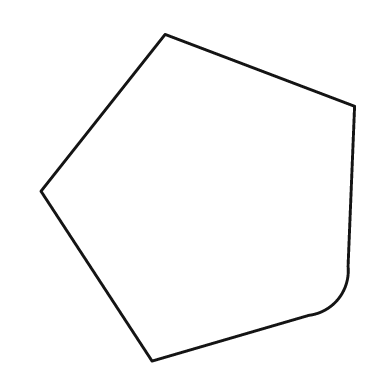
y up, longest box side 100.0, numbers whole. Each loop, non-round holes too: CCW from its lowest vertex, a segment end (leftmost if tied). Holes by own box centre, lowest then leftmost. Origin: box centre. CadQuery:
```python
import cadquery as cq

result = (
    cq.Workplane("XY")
    .moveTo(-14.0, -50.0)
    .lineTo(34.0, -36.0)
    .threePointArc((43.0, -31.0), (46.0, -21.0))
    .lineTo(48.0, 28.0)
    .lineTo(-10.0, 50.0)
    .lineTo(-48.0, 2.0)
    .close()
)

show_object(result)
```